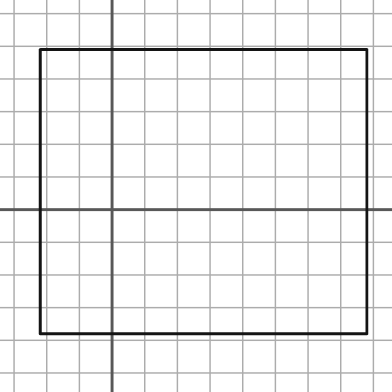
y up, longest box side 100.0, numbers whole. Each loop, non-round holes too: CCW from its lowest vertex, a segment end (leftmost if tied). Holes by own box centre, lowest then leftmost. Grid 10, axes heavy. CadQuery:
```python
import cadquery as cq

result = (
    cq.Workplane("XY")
    .moveTo(-22.0, -38.0)
    .lineTo(78.0, -38.0)
    .lineTo(78.0, 49.0)
    .lineTo(-22.0, 49.0)
    .close()
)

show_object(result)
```